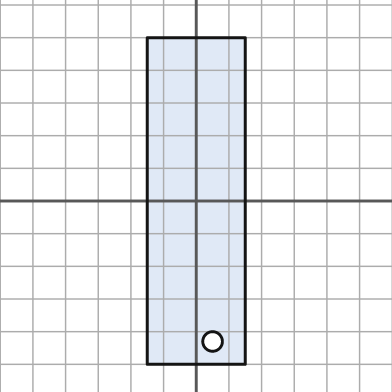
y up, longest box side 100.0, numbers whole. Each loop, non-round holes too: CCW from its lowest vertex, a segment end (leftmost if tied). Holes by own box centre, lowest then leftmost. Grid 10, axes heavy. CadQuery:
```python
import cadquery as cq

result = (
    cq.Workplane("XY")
    .moveTo(-15.0, -50.0)
    .lineTo(15.0, -50.0)
    .lineTo(15.0, 50.0)
    .lineTo(-15.0, 50.0)
    .close()
    .moveTo(5.0, -43.0)
    .circle(3.0)
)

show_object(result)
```